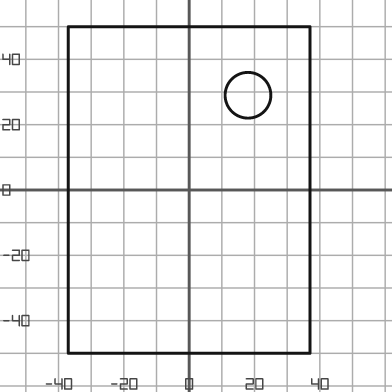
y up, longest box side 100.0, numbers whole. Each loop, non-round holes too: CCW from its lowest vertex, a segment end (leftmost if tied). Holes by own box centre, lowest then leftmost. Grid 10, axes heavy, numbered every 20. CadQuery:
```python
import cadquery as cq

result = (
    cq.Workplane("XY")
    .moveTo(-37.0, -50.0)
    .lineTo(37.0, -50.0)
    .lineTo(37.0, 50.0)
    .lineTo(-37.0, 50.0)
    .close()
    .moveTo(18.0, 29.0)
    .circle(7.0)
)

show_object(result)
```